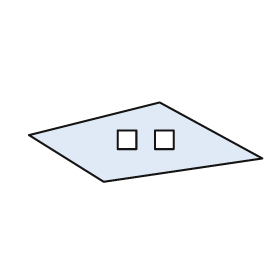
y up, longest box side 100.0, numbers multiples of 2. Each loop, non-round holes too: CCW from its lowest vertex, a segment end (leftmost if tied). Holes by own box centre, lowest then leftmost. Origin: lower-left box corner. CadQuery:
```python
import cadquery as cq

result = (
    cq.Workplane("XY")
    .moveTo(32.0, 0.0)
    .lineTo(100.0, 10.0)
    .lineTo(56.0, 34.0)
    .lineTo(0.0, 20.0)
    .close()
    .moveTo(38.0, 14.0)
    .lineTo(46.0, 14.0)
    .lineTo(46.0, 22.0)
    .lineTo(38.0, 22.0)
    .close()
    .moveTo(54.0, 14.0)
    .lineTo(62.0, 14.0)
    .lineTo(62.0, 22.0)
    .lineTo(54.0, 22.0)
    .close()
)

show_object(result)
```